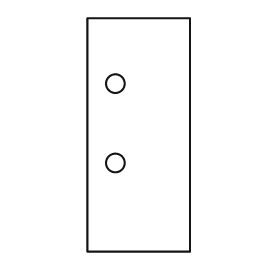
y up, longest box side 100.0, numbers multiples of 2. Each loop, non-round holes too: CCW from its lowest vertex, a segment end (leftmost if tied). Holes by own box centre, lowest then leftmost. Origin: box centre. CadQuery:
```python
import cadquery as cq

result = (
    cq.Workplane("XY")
    .moveTo(-22.0, -50.0)
    .lineTo(22.0, -50.0)
    .lineTo(22.0, 50.0)
    .lineTo(-22.0, 50.0)
    .close()
    .moveTo(-10.0, -12.0)
    .circle(4.0)
    .moveTo(-10.0, 22.0)
    .circle(4.0)
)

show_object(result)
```